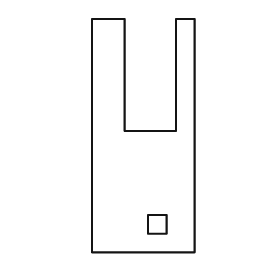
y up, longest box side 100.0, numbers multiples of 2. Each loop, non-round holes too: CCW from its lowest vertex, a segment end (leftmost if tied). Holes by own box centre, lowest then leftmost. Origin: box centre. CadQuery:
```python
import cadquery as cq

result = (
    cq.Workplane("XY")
    .moveTo(-22.0, -50.0)
    .lineTo(22.0, -50.0)
    .lineTo(22.0, 50.0)
    .lineTo(14.0, 50.0)
    .lineTo(14.0, 2.0)
    .lineTo(-8.0, 2.0)
    .lineTo(-8.0, 50.0)
    .lineTo(-22.0, 50.0)
    .close()
    .moveTo(2.0, -42.0)
    .lineTo(10.0, -42.0)
    .lineTo(10.0, -34.0)
    .lineTo(2.0, -34.0)
    .close()
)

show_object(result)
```